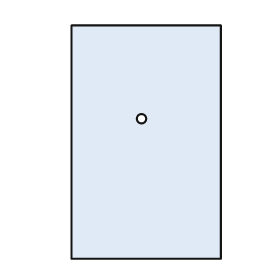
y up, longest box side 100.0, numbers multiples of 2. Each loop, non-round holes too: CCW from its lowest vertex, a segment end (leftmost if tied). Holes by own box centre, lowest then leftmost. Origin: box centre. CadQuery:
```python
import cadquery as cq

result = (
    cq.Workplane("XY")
    .moveTo(-32.0, -50.0)
    .lineTo(32.0, -50.0)
    .lineTo(32.0, 50.0)
    .lineTo(-32.0, 50.0)
    .close()
    .moveTo(-2.0, 10.0)
    .circle(2.0)
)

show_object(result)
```